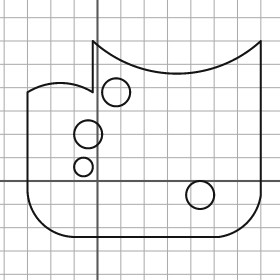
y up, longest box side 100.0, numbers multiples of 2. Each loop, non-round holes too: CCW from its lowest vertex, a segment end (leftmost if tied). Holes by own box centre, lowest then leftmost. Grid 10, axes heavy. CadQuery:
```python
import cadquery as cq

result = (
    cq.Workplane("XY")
    .moveTo(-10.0, -24.0)
    .lineTo(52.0, -24.0)
    .threePointArc((64.0, -18.0), (70.0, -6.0))
    .lineTo(70.0, 60.0)
    .threePointArc((34.0, 46.0), (-2.0, 60.0))
    .lineTo(-2.0, 38.0)
    .threePointArc((-16.0, 42.0), (-30.0, 38.0))
    .lineTo(-30.0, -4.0)
    .threePointArc((-24.0, -18.0), (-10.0, -24.0))
    .close()
    .moveTo(44.0, -6.0)
    .circle(6.0)
    .moveTo(-6.0, 6.0)
    .circle(4.0)
    .moveTo(-4.0, 20.0)
    .circle(6.0)
    .moveTo(8.0, 38.0)
    .circle(6.0)
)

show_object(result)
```